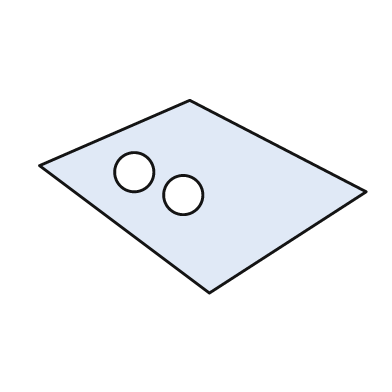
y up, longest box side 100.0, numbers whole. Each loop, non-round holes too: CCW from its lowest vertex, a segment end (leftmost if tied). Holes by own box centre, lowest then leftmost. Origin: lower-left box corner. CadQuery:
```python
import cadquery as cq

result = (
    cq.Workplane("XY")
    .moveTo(52.0, 0.0)
    .lineTo(100.0, 31.0)
    .lineTo(46.0, 59.0)
    .lineTo(0.0, 39.0)
    .close()
    .moveTo(44.0, 30.0)
    .circle(6.0)
    .moveTo(29.0, 37.0)
    .circle(6.0)
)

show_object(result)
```